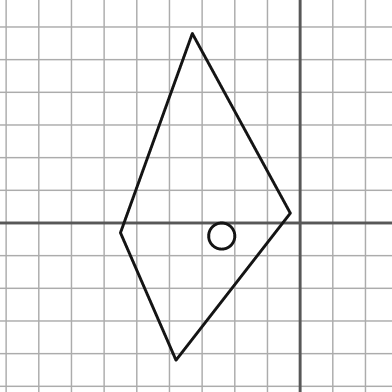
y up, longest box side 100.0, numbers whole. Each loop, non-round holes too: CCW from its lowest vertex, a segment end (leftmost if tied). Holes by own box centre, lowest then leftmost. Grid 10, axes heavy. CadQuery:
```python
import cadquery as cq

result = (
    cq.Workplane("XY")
    .moveTo(-38.0, -42.0)
    .lineTo(-3.0, 3.0)
    .lineTo(-33.0, 58.0)
    .lineTo(-55.0, -3.0)
    .close()
    .moveTo(-24.0, -4.0)
    .circle(4.0)
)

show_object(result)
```